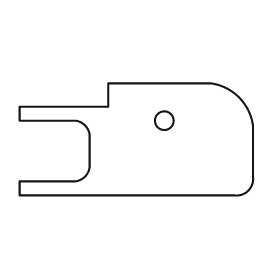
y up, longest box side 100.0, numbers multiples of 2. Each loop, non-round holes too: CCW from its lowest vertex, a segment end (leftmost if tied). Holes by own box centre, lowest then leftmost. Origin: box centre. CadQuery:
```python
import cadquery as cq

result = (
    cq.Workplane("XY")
    .moveTo(-50.0, -24.0)
    .lineTo(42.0, -24.0)
    .threePointArc((48.0, -22.0), (50.0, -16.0))
    .lineTo(50.0, 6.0)
    .threePointArc((44.0, 18.0), (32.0, 24.0))
    .lineTo(-12.0, 24.0)
    .lineTo(-12.0, 14.0)
    .lineTo(-50.0, 14.0)
    .lineTo(-50.0, 8.0)
    .lineTo(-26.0, 8.0)
    .threePointArc((-22.0, 6.0), (-20.0, 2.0))
    .lineTo(-20.0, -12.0)
    .threePointArc((-22.0, -16.0), (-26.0, -18.0))
    .lineTo(-50.0, -18.0)
    .close()
    .moveTo(12.0, 8.0)
    .circle(4.0)
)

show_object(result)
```